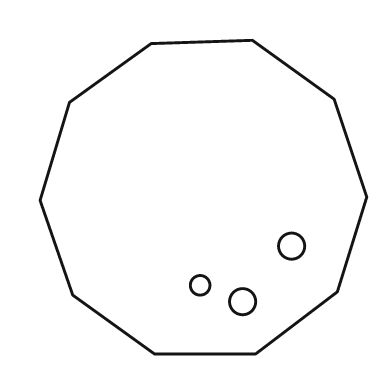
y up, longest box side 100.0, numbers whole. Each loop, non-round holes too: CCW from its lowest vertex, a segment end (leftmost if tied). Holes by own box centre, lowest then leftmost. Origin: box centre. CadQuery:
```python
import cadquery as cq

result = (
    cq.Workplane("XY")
    .moveTo(-15.0, -48.0)
    .lineTo(16.0, -48.0)
    .lineTo(41.0, -29.0)
    .lineTo(50.0, 0.0)
    .lineTo(40.0, 30.0)
    .lineTo(15.0, 48.0)
    .lineTo(-16.0, 47.0)
    .lineTo(-41.0, 29.0)
    .lineTo(-50.0, -1.0)
    .lineTo(-40.0, -30.0)
    .close()
    .moveTo(12.0, -32.0)
    .circle(4.0)
    .moveTo(-1.0, -27.0)
    .circle(3.0)
    .moveTo(27.0, -15.0)
    .circle(4.0)
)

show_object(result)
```